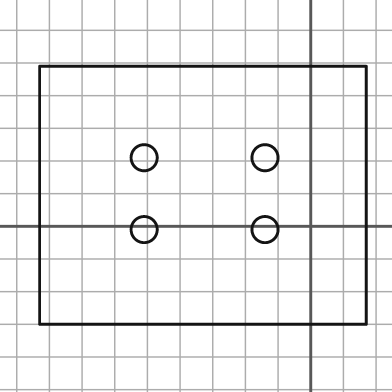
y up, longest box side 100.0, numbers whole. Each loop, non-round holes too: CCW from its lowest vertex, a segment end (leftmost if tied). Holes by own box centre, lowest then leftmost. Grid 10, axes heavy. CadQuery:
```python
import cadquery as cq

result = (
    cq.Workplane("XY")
    .moveTo(-83.0, -30.0)
    .lineTo(17.0, -30.0)
    .lineTo(17.0, 49.0)
    .lineTo(-83.0, 49.0)
    .close()
    .moveTo(-51.0, -1.0)
    .circle(4.0)
    .moveTo(-14.0, -1.0)
    .circle(4.0)
    .moveTo(-51.0, 21.0)
    .circle(4.0)
    .moveTo(-14.0, 21.0)
    .circle(4.0)
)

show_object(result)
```